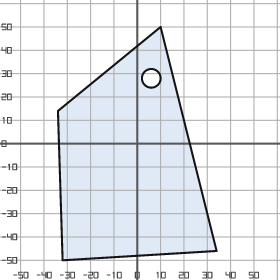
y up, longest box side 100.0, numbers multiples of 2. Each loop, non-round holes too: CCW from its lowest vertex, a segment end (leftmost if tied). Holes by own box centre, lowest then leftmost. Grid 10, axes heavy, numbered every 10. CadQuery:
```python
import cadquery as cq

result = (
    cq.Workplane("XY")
    .moveTo(-32.0, -50.0)
    .lineTo(34.0, -46.0)
    .lineTo(10.0, 50.0)
    .lineTo(-34.0, 14.0)
    .close()
    .moveTo(6.0, 28.0)
    .circle(4.0)
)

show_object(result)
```